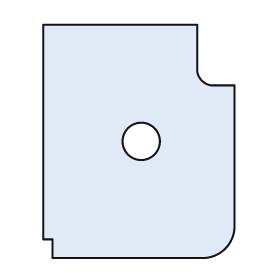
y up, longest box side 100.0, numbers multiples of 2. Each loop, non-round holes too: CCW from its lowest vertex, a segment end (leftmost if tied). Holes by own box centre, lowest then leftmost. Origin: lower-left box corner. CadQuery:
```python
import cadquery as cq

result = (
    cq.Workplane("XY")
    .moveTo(4.0, 0.0)
    .lineTo(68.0, 0.0)
    .threePointArc((78.0, 4.0), (82.0, 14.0))
    .lineTo(82.0, 74.0)
    .lineTo(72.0, 74.0)
    .threePointArc((68.0, 76.0), (66.0, 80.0))
    .lineTo(66.0, 100.0)
    .lineTo(0.0, 100.0)
    .lineTo(0.0, 8.0)
    .lineTo(4.0, 8.0)
    .close()
    .moveTo(42.0, 50.0)
    .circle(8.0)
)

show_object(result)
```